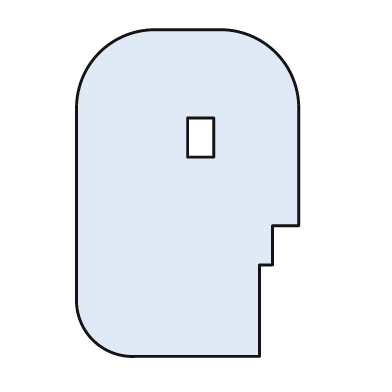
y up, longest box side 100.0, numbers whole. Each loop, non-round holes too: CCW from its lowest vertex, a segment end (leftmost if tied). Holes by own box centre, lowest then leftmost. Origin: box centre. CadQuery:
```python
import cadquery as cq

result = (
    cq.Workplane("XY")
    .moveTo(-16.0, -50.0)
    .lineTo(22.0, -50.0)
    .lineTo(22.0, -22.0)
    .lineTo(26.0, -22.0)
    .lineTo(26.0, -10.0)
    .lineTo(34.0, -10.0)
    .lineTo(34.0, 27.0)
    .threePointArc((27.0, 43.0), (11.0, 50.0))
    .lineTo(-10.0, 50.0)
    .threePointArc((-27.0, 43.0), (-34.0, 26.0))
    .lineTo(-34.0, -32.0)
    .threePointArc((-29.0, -45.0), (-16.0, -50.0))
    .close()
    .moveTo(0.0, 11.0)
    .lineTo(8.0, 11.0)
    .lineTo(8.0, 23.0)
    .lineTo(0.0, 23.0)
    .close()
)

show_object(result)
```